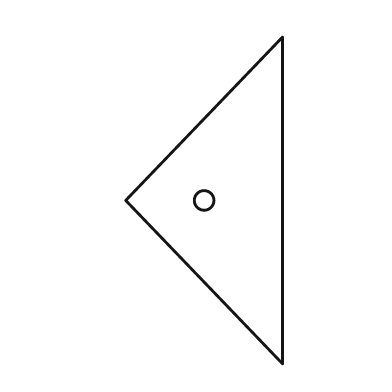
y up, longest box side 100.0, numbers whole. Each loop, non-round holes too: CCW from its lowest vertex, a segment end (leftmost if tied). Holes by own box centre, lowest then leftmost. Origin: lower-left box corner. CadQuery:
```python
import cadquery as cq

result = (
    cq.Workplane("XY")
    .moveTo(48.0, 0.0)
    .lineTo(48.0, 100.0)
    .lineTo(0.0, 50.0)
    .close()
    .moveTo(24.0, 50.0)
    .circle(3.0)
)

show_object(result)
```